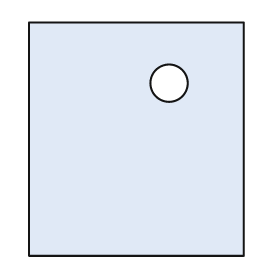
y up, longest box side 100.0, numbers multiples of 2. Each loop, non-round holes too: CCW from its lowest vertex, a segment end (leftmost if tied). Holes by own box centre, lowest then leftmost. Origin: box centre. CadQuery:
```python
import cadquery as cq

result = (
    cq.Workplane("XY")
    .moveTo(-46.0, -50.0)
    .lineTo(46.0, -50.0)
    .lineTo(46.0, 50.0)
    .lineTo(-46.0, 50.0)
    .close()
    .moveTo(14.0, 24.0)
    .circle(8.0)
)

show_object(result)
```